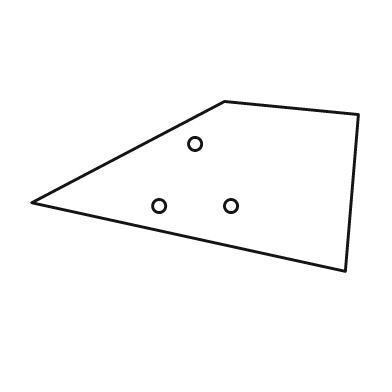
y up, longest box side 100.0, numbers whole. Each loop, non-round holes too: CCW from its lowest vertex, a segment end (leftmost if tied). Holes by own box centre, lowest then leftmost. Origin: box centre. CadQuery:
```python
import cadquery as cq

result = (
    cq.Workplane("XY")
    .moveTo(46.0, -26.0)
    .lineTo(50.0, 22.0)
    .lineTo(9.0, 26.0)
    .lineTo(-50.0, -5.0)
    .close()
    .moveTo(-11.0, -6.0)
    .circle(2.0)
    .moveTo(11.0, -6.0)
    .circle(2.0)
    .moveTo(0.0, 13.0)
    .circle(2.0)
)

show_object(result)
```